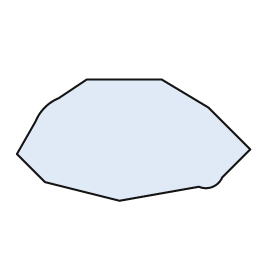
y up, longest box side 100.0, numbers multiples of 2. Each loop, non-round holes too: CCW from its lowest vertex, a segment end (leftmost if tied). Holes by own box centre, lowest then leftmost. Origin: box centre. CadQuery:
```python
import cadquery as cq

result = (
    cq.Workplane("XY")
    .moveTo(-6.0, -26.0)
    .lineTo(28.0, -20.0)
    .threePointArc((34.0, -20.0), (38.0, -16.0))
    .lineTo(50.0, -4.0)
    .lineTo(32.0, 14.0)
    .lineTo(12.0, 26.0)
    .lineTo(-20.0, 26.0)
    .lineTo(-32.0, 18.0)
    .threePointArc((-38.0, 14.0), (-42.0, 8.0))
    .lineTo(-50.0, -6.0)
    .lineTo(-38.0, -18.0)
    .close()
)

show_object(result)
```